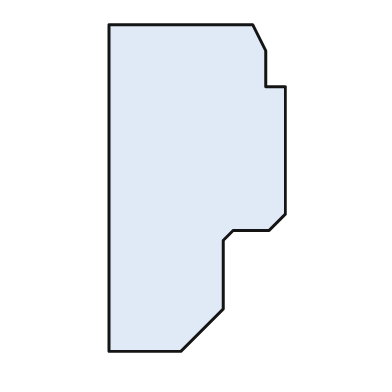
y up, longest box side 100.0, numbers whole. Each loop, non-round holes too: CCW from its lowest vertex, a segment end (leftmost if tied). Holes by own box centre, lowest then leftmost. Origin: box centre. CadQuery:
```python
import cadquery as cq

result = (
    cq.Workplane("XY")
    .moveTo(-27.0, -50.0)
    .lineTo(-5.0, -50.0)
    .lineTo(8.0, -37.0)
    .lineTo(8.0, -16.0)
    .lineTo(11.0, -13.0)
    .lineTo(22.0, -13.0)
    .lineTo(27.0, -8.0)
    .lineTo(27.0, 31.0)
    .lineTo(21.0, 31.0)
    .lineTo(21.0, 42.0)
    .lineTo(17.0, 50.0)
    .lineTo(-27.0, 50.0)
    .close()
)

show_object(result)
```